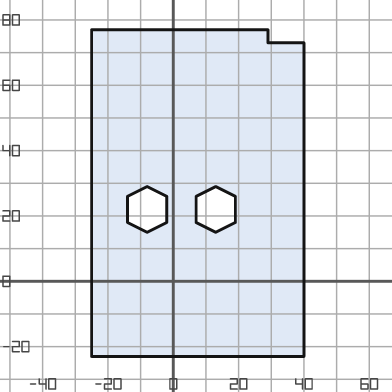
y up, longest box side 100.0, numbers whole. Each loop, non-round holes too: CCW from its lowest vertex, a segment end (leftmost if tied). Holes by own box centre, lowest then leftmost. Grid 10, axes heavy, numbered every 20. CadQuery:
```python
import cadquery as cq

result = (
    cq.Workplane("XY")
    .moveTo(-25.0, -23.0)
    .lineTo(40.0, -23.0)
    .lineTo(40.0, 73.0)
    .lineTo(29.0, 73.0)
    .lineTo(29.0, 77.0)
    .lineTo(-25.0, 77.0)
    .close()
    .moveTo(-8.0, 15.0)
    .lineTo(-2.0, 18.0)
    .lineTo(-2.0, 26.0)
    .lineTo(-8.0, 29.0)
    .lineTo(-14.0, 26.0)
    .lineTo(-14.0, 18.0)
    .close()
    .moveTo(13.0, 15.0)
    .lineTo(19.0, 18.0)
    .lineTo(19.0, 26.0)
    .lineTo(13.0, 29.0)
    .lineTo(7.0, 26.0)
    .lineTo(7.0, 18.0)
    .close()
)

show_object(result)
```